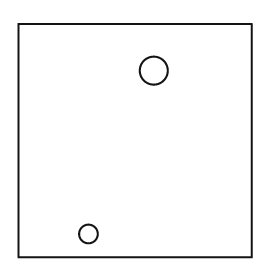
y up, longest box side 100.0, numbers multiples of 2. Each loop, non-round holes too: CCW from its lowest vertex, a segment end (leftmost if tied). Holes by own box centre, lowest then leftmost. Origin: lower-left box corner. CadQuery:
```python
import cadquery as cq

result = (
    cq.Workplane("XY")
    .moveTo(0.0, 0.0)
    .lineTo(100.0, 0.0)
    .lineTo(100.0, 100.0)
    .lineTo(0.0, 100.0)
    .close()
    .moveTo(30.0, 10.0)
    .circle(4.0)
    .moveTo(58.0, 80.0)
    .circle(6.0)
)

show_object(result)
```